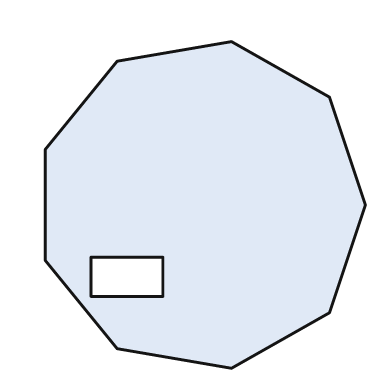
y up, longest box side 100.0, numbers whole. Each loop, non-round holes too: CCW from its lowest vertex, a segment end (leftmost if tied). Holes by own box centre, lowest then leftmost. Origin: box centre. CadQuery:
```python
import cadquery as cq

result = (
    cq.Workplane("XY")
    .moveTo(8.0, -50.0)
    .lineTo(38.0, -33.0)
    .lineTo(49.0, 0.0)
    .lineTo(38.0, 33.0)
    .lineTo(8.0, 50.0)
    .lineTo(-27.0, 44.0)
    .lineTo(-49.0, 17.0)
    .lineTo(-49.0, -17.0)
    .lineTo(-27.0, -44.0)
    .close()
    .moveTo(-35.0, -28.0)
    .lineTo(-13.0, -28.0)
    .lineTo(-13.0, -16.0)
    .lineTo(-35.0, -16.0)
    .close()
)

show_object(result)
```